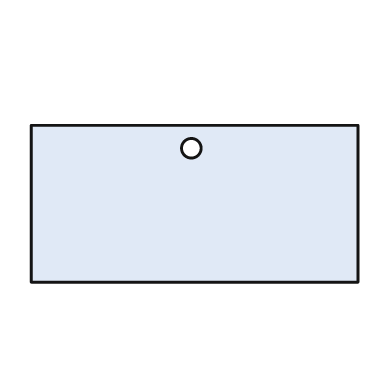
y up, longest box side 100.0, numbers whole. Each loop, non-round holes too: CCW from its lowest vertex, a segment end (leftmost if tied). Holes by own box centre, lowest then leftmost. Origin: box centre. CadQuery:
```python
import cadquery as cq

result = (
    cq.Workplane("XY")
    .moveTo(-50.0, -24.0)
    .lineTo(50.0, -24.0)
    .lineTo(50.0, 24.0)
    .lineTo(-50.0, 24.0)
    .close()
    .moveTo(-1.0, 17.0)
    .circle(3.0)
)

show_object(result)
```